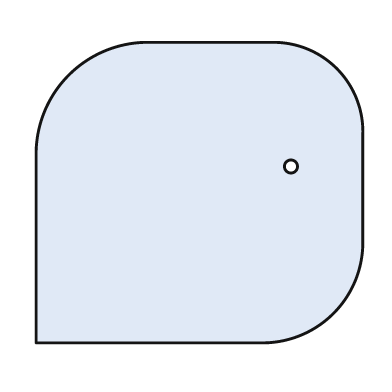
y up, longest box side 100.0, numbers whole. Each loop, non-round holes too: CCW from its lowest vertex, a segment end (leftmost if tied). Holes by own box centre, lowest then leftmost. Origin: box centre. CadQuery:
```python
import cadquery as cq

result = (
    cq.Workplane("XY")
    .moveTo(-50.0, -46.0)
    .lineTo(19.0, -46.0)
    .threePointArc((41.0, -37.0), (50.0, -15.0))
    .lineTo(50.0, 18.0)
    .threePointArc((42.0, 38.0), (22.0, 46.0))
    .lineTo(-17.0, 46.0)
    .threePointArc((-40.0, 36.0), (-50.0, 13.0))
    .close()
    .moveTo(28.0, 8.0)
    .circle(2.0)
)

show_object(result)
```